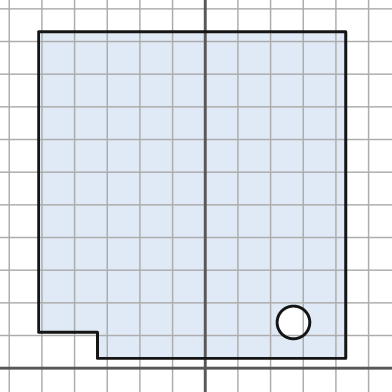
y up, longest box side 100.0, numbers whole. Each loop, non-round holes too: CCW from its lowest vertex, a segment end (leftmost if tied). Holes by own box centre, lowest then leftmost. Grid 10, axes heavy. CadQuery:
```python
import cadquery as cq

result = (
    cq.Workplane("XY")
    .moveTo(-33.0, 3.0)
    .lineTo(43.0, 3.0)
    .lineTo(43.0, 103.0)
    .lineTo(-51.0, 103.0)
    .lineTo(-51.0, 11.0)
    .lineTo(-33.0, 11.0)
    .close()
    .moveTo(27.0, 14.0)
    .circle(5.0)
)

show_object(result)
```